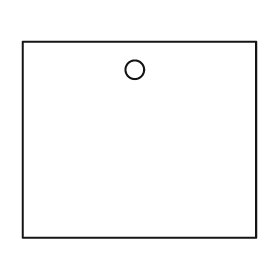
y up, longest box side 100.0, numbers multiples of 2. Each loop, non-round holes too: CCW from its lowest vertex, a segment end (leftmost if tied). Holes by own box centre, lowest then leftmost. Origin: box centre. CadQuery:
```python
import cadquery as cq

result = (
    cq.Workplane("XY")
    .moveTo(-50.0, -42.0)
    .lineTo(50.0, -42.0)
    .lineTo(50.0, 42.0)
    .lineTo(-50.0, 42.0)
    .close()
    .moveTo(-2.0, 30.0)
    .circle(4.0)
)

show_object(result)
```